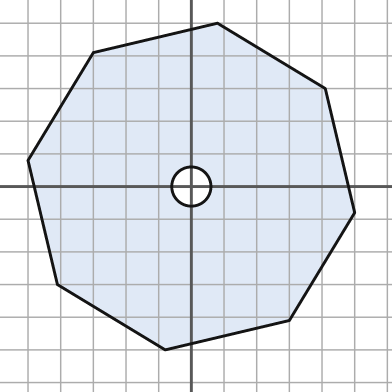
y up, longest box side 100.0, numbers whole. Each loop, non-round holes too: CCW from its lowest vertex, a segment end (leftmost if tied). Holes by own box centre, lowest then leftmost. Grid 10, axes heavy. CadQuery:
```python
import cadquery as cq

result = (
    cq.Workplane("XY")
    .moveTo(-8.0, -50.0)
    .lineTo(30.0, -41.0)
    .lineTo(50.0, -8.0)
    .lineTo(41.0, 30.0)
    .lineTo(8.0, 50.0)
    .lineTo(-30.0, 41.0)
    .lineTo(-50.0, 8.0)
    .lineTo(-41.0, -30.0)
    .close()
    .moveTo(0.0, 0.0)
    .circle(6.0)
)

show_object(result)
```